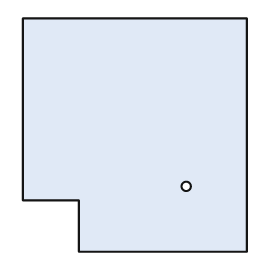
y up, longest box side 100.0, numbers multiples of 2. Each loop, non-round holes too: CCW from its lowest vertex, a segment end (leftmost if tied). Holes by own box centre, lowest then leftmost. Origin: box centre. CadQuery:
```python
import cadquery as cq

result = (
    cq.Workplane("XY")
    .moveTo(-24.0, -50.0)
    .lineTo(48.0, -50.0)
    .lineTo(48.0, 50.0)
    .lineTo(-48.0, 50.0)
    .lineTo(-48.0, -28.0)
    .lineTo(-24.0, -28.0)
    .close()
    .moveTo(22.0, -22.0)
    .circle(2.0)
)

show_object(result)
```